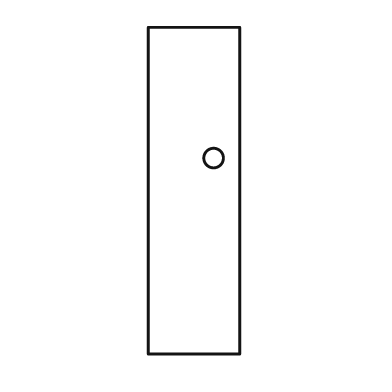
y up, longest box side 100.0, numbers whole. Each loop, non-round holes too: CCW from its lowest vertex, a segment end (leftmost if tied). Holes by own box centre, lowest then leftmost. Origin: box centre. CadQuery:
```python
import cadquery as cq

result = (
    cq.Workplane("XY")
    .moveTo(-14.0, -50.0)
    .lineTo(14.0, -50.0)
    .lineTo(14.0, 50.0)
    .lineTo(-14.0, 50.0)
    .close()
    .moveTo(6.0, 10.0)
    .circle(3.0)
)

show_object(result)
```